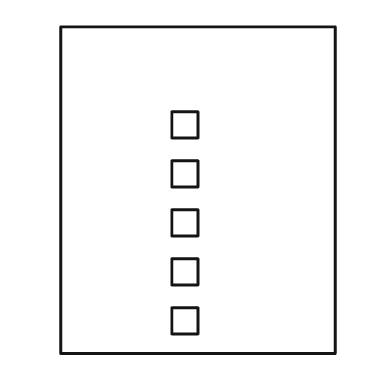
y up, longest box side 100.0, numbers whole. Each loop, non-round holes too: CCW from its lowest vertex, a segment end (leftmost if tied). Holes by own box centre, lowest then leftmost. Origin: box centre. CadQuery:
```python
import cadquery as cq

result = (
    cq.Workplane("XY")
    .moveTo(-42.0, -50.0)
    .lineTo(42.0, -50.0)
    .lineTo(42.0, 50.0)
    .lineTo(-42.0, 50.0)
    .close()
    .moveTo(-8.0, -44.0)
    .lineTo(0.0, -44.0)
    .lineTo(0.0, -36.0)
    .lineTo(-8.0, -36.0)
    .close()
    .moveTo(-8.0, -29.0)
    .lineTo(0.0, -29.0)
    .lineTo(0.0, -21.0)
    .lineTo(-8.0, -21.0)
    .close()
    .moveTo(-8.0, -14.0)
    .lineTo(0.0, -14.0)
    .lineTo(0.0, -6.0)
    .lineTo(-8.0, -6.0)
    .close()
    .moveTo(-8.0, 1.0)
    .lineTo(0.0, 1.0)
    .lineTo(0.0, 9.0)
    .lineTo(-8.0, 9.0)
    .close()
    .moveTo(-8.0, 16.0)
    .lineTo(0.0, 16.0)
    .lineTo(0.0, 24.0)
    .lineTo(-8.0, 24.0)
    .close()
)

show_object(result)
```